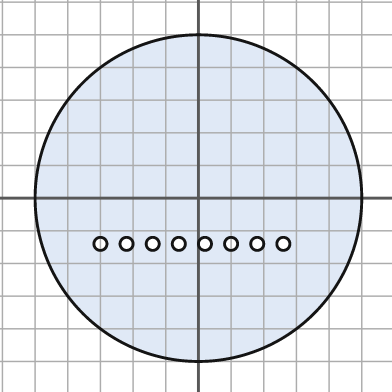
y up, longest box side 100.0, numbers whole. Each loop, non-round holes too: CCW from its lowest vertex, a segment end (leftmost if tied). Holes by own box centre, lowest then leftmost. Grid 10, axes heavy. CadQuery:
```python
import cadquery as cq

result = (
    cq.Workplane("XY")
    .moveTo(0.0, 0.0)
    .circle(50.0)
    .moveTo(-30.0, -14.0)
    .circle(2.0)
    .moveTo(-22.0, -14.0)
    .circle(2.0)
    .moveTo(-14.0, -14.0)
    .circle(2.0)
    .moveTo(-6.0, -14.0)
    .circle(2.0)
    .moveTo(2.0, -14.0)
    .circle(2.0)
    .moveTo(10.0, -14.0)
    .circle(2.0)
    .moveTo(18.0, -14.0)
    .circle(2.0)
    .moveTo(26.0, -14.0)
    .circle(2.0)
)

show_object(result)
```